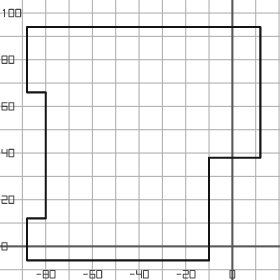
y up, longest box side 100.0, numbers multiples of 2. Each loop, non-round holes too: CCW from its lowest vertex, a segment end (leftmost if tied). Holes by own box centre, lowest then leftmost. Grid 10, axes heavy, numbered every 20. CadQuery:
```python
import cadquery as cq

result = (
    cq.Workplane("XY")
    .moveTo(-88.0, -6.0)
    .lineTo(-10.0, -6.0)
    .lineTo(-10.0, 38.0)
    .lineTo(12.0, 38.0)
    .lineTo(12.0, 94.0)
    .lineTo(-88.0, 94.0)
    .lineTo(-88.0, 66.0)
    .lineTo(-80.0, 66.0)
    .lineTo(-80.0, 12.0)
    .lineTo(-88.0, 12.0)
    .close()
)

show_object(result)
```